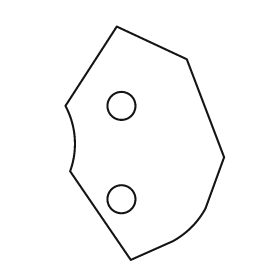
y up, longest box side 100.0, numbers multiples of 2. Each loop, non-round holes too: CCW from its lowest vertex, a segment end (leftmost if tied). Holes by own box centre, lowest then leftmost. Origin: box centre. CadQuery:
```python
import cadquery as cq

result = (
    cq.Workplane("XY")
    .moveTo(-6.0, -50.0)
    .lineTo(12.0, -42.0)
    .threePointArc((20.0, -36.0), (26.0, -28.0))
    .lineTo(34.0, -6.0)
    .lineTo(18.0, 36.0)
    .lineTo(-12.0, 50.0)
    .lineTo(-34.0, 16.0)
    .threePointArc((-30.0, 2.0), (-32.0, -12.0))
    .close()
    .moveTo(-10.0, -24.0)
    .circle(6.0)
    .moveTo(-10.0, 16.0)
    .circle(6.0)
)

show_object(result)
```